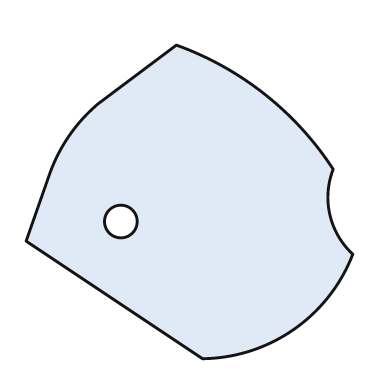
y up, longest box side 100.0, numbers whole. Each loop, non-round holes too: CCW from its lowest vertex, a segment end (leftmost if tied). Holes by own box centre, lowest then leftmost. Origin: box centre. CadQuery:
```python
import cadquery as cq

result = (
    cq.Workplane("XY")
    .moveTo(4.0, -48.0)
    .threePointArc((32.0, -39.0), (50.0, -16.0))
    .threePointArc((43.0, -4.0), (44.0, 10.0))
    .threePointArc((23.0, 33.0), (-4.0, 48.0))
    .lineTo(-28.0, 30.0)
    .threePointArc((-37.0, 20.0), (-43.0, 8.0))
    .lineTo(-50.0, -12.0)
    .close()
    .moveTo(-21.0, -6.0)
    .circle(5.0)
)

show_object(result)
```